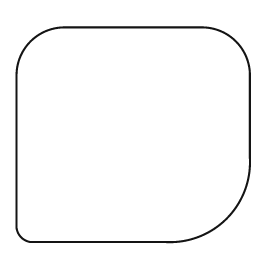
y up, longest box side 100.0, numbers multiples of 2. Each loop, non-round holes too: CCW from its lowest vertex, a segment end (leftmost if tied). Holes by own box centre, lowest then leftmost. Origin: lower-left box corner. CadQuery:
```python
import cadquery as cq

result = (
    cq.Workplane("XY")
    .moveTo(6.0, 0.0)
    .lineTo(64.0, 0.0)
    .threePointArc((90.0, 10.0), (100.0, 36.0))
    .lineTo(100.0, 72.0)
    .threePointArc((94.0, 86.0), (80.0, 92.0))
    .lineTo(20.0, 92.0)
    .threePointArc((6.0, 86.0), (0.0, 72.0))
    .lineTo(0.0, 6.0)
    .threePointArc((2.0, 2.0), (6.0, 0.0))
    .close()
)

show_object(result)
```